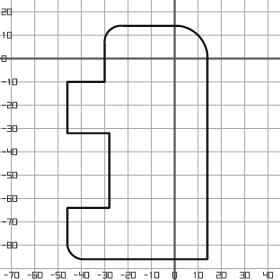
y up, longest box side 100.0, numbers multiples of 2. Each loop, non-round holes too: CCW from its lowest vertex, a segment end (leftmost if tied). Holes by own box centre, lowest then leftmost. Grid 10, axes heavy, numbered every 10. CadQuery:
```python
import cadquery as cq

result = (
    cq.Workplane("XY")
    .moveTo(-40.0, -86.0)
    .lineTo(14.0, -86.0)
    .lineTo(14.0, 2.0)
    .threePointArc((10.0, 10.0), (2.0, 14.0))
    .lineTo(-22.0, 14.0)
    .threePointArc((-28.0, 12.0), (-30.0, 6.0))
    .lineTo(-30.0, -10.0)
    .lineTo(-46.0, -10.0)
    .lineTo(-46.0, -32.0)
    .lineTo(-28.0, -32.0)
    .lineTo(-28.0, -64.0)
    .lineTo(-46.0, -64.0)
    .lineTo(-46.0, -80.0)
    .threePointArc((-44.0, -84.0), (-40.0, -86.0))
    .close()
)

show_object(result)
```